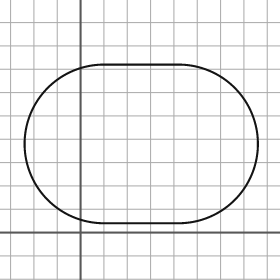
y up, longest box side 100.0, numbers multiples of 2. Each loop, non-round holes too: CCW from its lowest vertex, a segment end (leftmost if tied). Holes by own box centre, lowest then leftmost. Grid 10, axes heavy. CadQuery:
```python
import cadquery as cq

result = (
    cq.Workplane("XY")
    .moveTo(10.0, 4.0)
    .lineTo(42.0, 4.0)
    .threePointArc((76.0, 38.0), (42.0, 72.0))
    .lineTo(10.0, 72.0)
    .threePointArc((-24.0, 38.0), (10.0, 4.0))
    .close()
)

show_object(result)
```